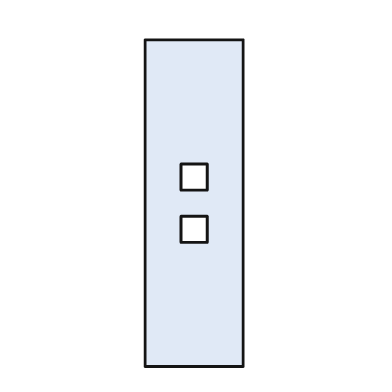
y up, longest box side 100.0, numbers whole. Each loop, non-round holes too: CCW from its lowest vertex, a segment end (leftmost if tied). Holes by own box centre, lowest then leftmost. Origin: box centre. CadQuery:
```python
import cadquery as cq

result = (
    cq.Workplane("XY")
    .moveTo(-15.0, -50.0)
    .lineTo(15.0, -50.0)
    .lineTo(15.0, 50.0)
    .lineTo(-15.0, 50.0)
    .close()
    .moveTo(-4.0, -12.0)
    .lineTo(4.0, -12.0)
    .lineTo(4.0, -4.0)
    .lineTo(-4.0, -4.0)
    .close()
    .moveTo(-4.0, 4.0)
    .lineTo(4.0, 4.0)
    .lineTo(4.0, 12.0)
    .lineTo(-4.0, 12.0)
    .close()
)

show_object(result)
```